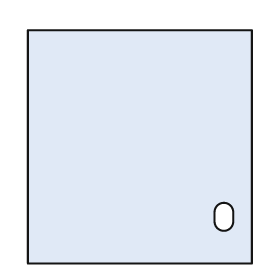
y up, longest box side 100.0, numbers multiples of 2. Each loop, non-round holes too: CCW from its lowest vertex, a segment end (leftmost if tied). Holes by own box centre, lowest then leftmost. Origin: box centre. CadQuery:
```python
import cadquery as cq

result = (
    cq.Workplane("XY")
    .moveTo(-48.0, -50.0)
    .lineTo(48.0, -50.0)
    .lineTo(48.0, 50.0)
    .lineTo(-48.0, 50.0)
    .close()
    .moveTo(32.0, -32.0)
    .threePointArc((36.0, -36.0), (40.0, -32.0))
    .lineTo(40.0, -28.0)
    .threePointArc((36.0, -24.0), (32.0, -28.0))
    .close()
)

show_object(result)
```